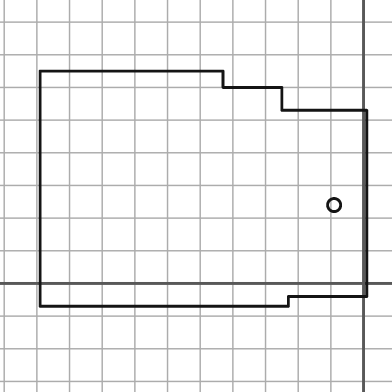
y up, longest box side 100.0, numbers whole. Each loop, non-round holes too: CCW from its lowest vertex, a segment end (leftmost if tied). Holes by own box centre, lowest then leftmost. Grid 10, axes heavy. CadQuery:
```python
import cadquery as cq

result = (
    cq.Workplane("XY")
    .moveTo(-99.0, -7.0)
    .lineTo(-23.0, -7.0)
    .lineTo(-23.0, -4.0)
    .lineTo(1.0, -4.0)
    .lineTo(1.0, 53.0)
    .lineTo(-25.0, 53.0)
    .lineTo(-25.0, 60.0)
    .lineTo(-43.0, 60.0)
    .lineTo(-43.0, 65.0)
    .lineTo(-99.0, 65.0)
    .close()
    .moveTo(-9.0, 24.0)
    .circle(2.0)
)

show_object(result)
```